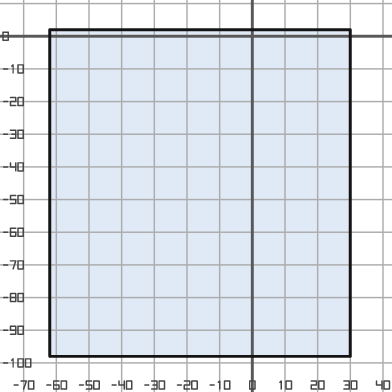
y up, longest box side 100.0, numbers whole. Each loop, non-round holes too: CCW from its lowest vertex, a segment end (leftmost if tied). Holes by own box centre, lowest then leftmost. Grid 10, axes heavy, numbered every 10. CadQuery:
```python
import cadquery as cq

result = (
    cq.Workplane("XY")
    .moveTo(-62.0, -98.0)
    .lineTo(30.0, -98.0)
    .lineTo(30.0, 2.0)
    .lineTo(-62.0, 2.0)
    .close()
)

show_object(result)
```